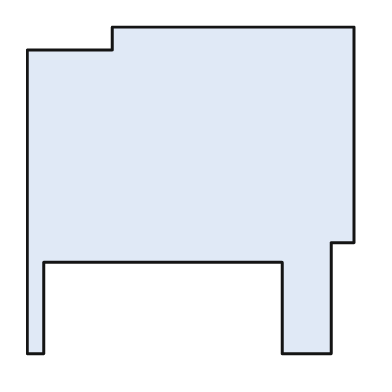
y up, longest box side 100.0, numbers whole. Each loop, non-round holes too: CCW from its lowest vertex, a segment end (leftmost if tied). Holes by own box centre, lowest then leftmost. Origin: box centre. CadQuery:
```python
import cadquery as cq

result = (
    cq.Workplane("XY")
    .moveTo(-50.0, -50.0)
    .lineTo(-45.0, -50.0)
    .lineTo(-45.0, -22.0)
    .lineTo(28.0, -22.0)
    .lineTo(28.0, -50.0)
    .lineTo(43.0, -50.0)
    .lineTo(43.0, -16.0)
    .lineTo(50.0, -16.0)
    .lineTo(50.0, 50.0)
    .lineTo(-24.0, 50.0)
    .lineTo(-24.0, 43.0)
    .lineTo(-50.0, 43.0)
    .close()
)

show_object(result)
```